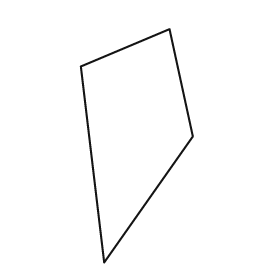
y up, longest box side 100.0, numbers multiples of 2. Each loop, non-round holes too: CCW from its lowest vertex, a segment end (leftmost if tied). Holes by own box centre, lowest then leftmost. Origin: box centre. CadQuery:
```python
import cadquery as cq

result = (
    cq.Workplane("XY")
    .moveTo(-14.0, -50.0)
    .lineTo(24.0, 4.0)
    .lineTo(14.0, 50.0)
    .lineTo(-24.0, 34.0)
    .close()
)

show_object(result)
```